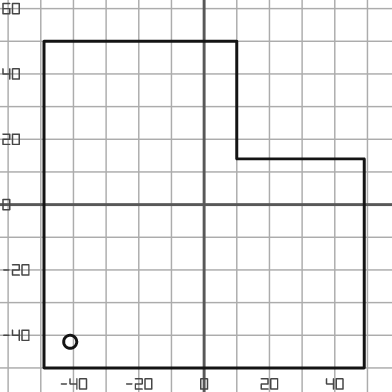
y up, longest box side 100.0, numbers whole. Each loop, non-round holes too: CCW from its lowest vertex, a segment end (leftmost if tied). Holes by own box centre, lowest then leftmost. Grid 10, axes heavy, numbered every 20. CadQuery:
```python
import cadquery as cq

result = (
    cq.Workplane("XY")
    .moveTo(-49.0, -50.0)
    .lineTo(49.0, -50.0)
    .lineTo(49.0, 14.0)
    .lineTo(10.0, 14.0)
    .lineTo(10.0, 50.0)
    .lineTo(-49.0, 50.0)
    .close()
    .moveTo(-41.0, -42.0)
    .circle(2.0)
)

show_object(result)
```